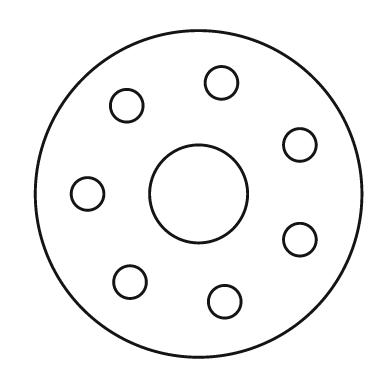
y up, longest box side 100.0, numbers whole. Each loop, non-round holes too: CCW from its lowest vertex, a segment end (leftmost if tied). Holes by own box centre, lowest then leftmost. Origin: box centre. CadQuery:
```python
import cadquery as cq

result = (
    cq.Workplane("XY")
    .moveTo(0.0, 0.0)
    .circle(50.0)
    .moveTo(8.0, -33.0)
    .circle(5.0)
    .moveTo(-21.0, -27.0)
    .circle(5.0)
    .moveTo(31.0, -14.0)
    .circle(5.0)
    .moveTo(-34.0, 0.0)
    .circle(5.0)
    .moveTo(0.0, 0.0)
    .circle(15.0)
    .moveTo(31.0, 15.0)
    .circle(5.0)
    .moveTo(-22.0, 27.0)
    .circle(5.0)
    .moveTo(7.0, 34.0)
    .circle(5.0)
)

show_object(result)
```